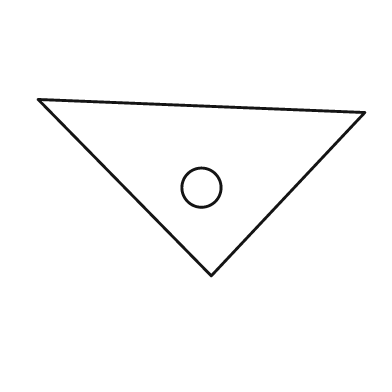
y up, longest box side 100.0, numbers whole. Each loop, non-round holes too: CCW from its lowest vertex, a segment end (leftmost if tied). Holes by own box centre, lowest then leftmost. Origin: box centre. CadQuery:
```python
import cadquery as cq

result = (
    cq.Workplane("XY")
    .moveTo(3.0, -27.0)
    .lineTo(50.0, 23.0)
    .lineTo(-50.0, 27.0)
    .close()
    .moveTo(0.0, 0.0)
    .circle(6.0)
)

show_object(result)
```